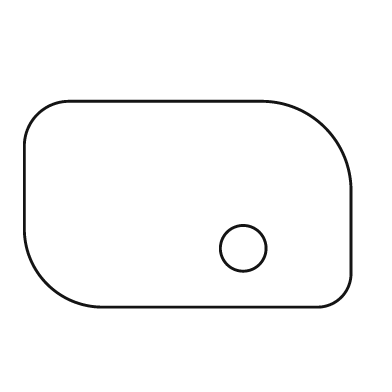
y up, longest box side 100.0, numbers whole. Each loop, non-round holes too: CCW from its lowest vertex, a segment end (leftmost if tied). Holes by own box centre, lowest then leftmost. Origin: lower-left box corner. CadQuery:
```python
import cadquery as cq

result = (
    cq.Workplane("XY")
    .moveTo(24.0, 0.0)
    .lineTo(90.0, 0.0)
    .threePointArc((97.0, 3.0), (100.0, 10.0))
    .lineTo(100.0, 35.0)
    .threePointArc((92.0, 55.0), (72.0, 63.0))
    .lineTo(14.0, 63.0)
    .threePointArc((4.0, 59.0), (0.0, 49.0))
    .lineTo(0.0, 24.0)
    .threePointArc((7.0, 7.0), (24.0, 0.0))
    .close()
    .moveTo(67.0, 18.0)
    .circle(7.0)
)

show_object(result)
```